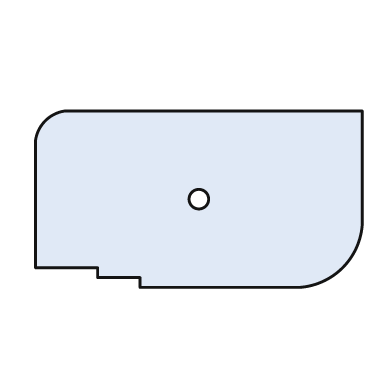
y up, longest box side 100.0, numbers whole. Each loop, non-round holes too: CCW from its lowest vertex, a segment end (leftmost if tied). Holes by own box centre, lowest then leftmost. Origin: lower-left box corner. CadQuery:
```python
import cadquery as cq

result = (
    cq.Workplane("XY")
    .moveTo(32.0, 0.0)
    .lineTo(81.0, 0.0)
    .threePointArc((94.0, 6.0), (100.0, 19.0))
    .lineTo(100.0, 54.0)
    .lineTo(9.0, 54.0)
    .threePointArc((3.0, 51.0), (0.0, 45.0))
    .lineTo(0.0, 6.0)
    .lineTo(19.0, 6.0)
    .lineTo(19.0, 3.0)
    .lineTo(32.0, 3.0)
    .close()
    .moveTo(50.0, 27.0)
    .circle(3.0)
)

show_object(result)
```